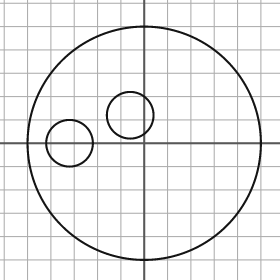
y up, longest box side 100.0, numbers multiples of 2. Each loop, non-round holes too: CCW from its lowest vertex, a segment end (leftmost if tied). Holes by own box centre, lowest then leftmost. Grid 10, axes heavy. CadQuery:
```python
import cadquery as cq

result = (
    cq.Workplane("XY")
    .moveTo(0.0, 0.0)
    .circle(50.0)
    .moveTo(-32.0, 0.0)
    .circle(10.0)
    .moveTo(-6.0, 12.0)
    .circle(10.0)
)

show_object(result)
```